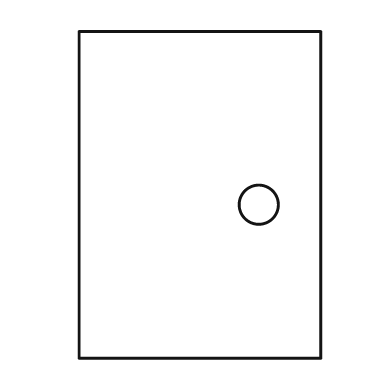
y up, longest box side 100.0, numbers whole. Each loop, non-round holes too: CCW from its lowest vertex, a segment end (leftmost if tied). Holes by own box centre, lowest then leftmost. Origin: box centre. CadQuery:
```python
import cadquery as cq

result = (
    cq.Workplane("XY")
    .moveTo(-37.0, -50.0)
    .lineTo(37.0, -50.0)
    .lineTo(37.0, 50.0)
    .lineTo(-37.0, 50.0)
    .close()
    .moveTo(18.0, -3.0)
    .circle(6.0)
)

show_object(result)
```